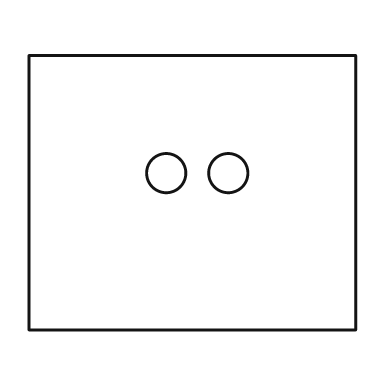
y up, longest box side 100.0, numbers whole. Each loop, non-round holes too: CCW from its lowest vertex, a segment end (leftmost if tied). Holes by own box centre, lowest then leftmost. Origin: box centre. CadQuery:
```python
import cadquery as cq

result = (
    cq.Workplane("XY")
    .moveTo(-50.0, -42.0)
    .lineTo(50.0, -42.0)
    .lineTo(50.0, 42.0)
    .lineTo(-50.0, 42.0)
    .close()
    .moveTo(-8.0, 6.0)
    .circle(6.0)
    .moveTo(11.0, 6.0)
    .circle(6.0)
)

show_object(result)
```